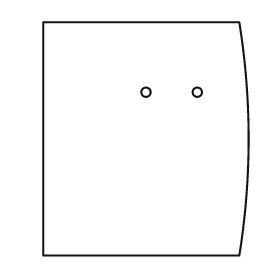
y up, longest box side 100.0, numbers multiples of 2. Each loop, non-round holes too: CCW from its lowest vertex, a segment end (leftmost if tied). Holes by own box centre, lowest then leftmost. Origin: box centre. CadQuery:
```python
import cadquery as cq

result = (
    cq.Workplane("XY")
    .moveTo(-44.0, -50.0)
    .lineTo(40.0, -50.0)
    .threePointArc((44.0, 0.0), (40.0, 50.0))
    .lineTo(-44.0, 50.0)
    .close()
    .moveTo(0.0, 20.0)
    .circle(2.0)
    .moveTo(22.0, 20.0)
    .circle(2.0)
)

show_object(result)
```